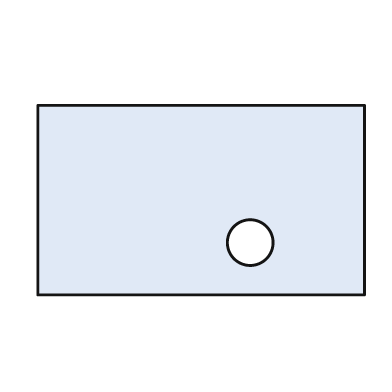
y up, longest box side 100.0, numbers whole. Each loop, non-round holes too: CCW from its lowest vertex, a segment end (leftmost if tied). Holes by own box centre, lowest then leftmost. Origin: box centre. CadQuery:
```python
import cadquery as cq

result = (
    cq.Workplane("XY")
    .moveTo(-50.0, -29.0)
    .lineTo(50.0, -29.0)
    .lineTo(50.0, 29.0)
    .lineTo(-50.0, 29.0)
    .close()
    .moveTo(15.0, -13.0)
    .circle(7.0)
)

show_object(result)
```